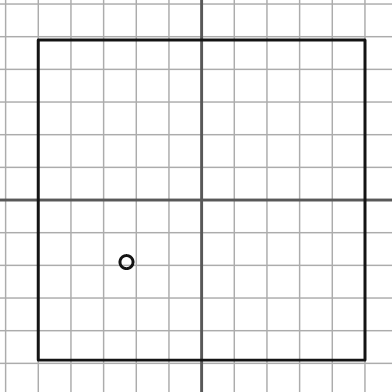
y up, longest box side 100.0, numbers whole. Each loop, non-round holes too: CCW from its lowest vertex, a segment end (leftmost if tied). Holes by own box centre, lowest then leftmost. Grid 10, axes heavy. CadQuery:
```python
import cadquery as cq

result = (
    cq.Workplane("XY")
    .moveTo(-50.0, -49.0)
    .lineTo(50.0, -49.0)
    .lineTo(50.0, 49.0)
    .lineTo(-50.0, 49.0)
    .close()
    .moveTo(-23.0, -19.0)
    .circle(2.0)
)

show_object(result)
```